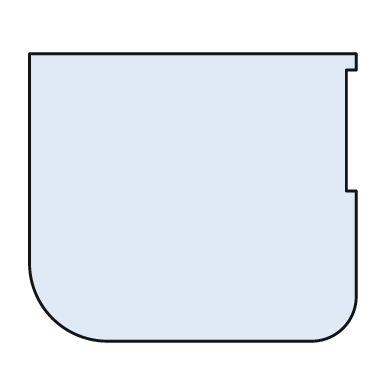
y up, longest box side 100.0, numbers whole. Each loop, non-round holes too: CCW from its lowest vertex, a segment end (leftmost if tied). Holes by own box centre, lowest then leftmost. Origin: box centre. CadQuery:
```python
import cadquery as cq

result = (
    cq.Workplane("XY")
    .moveTo(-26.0, -44.0)
    .lineTo(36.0, -44.0)
    .threePointArc((46.0, -40.0), (50.0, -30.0))
    .lineTo(50.0, 2.0)
    .lineTo(47.0, 2.0)
    .lineTo(47.0, 39.0)
    .lineTo(50.0, 39.0)
    .lineTo(50.0, 44.0)
    .lineTo(-50.0, 44.0)
    .lineTo(-50.0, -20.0)
    .threePointArc((-43.0, -37.0), (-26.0, -44.0))
    .close()
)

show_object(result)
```